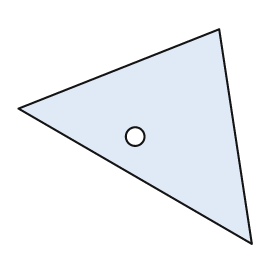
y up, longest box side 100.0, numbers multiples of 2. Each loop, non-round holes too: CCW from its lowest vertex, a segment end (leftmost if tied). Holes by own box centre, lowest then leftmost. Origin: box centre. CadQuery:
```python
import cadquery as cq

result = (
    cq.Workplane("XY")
    .moveTo(50.0, -46.0)
    .lineTo(36.0, 46.0)
    .lineTo(-50.0, 12.0)
    .close()
    .moveTo(0.0, 0.0)
    .circle(4.0)
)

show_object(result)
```